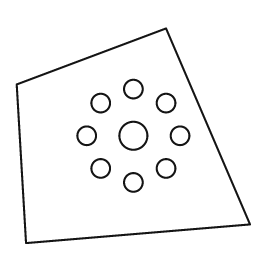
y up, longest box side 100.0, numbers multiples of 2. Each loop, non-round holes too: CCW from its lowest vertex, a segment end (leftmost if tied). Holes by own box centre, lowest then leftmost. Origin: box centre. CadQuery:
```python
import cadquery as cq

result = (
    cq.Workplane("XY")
    .moveTo(-46.0, -46.0)
    .lineTo(50.0, -38.0)
    .lineTo(14.0, 46.0)
    .lineTo(-50.0, 22.0)
    .close()
    .moveTo(0.0, -20.0)
    .circle(4.0)
    .moveTo(-14.0, -14.0)
    .circle(4.0)
    .moveTo(14.0, -14.0)
    .circle(4.0)
    .moveTo(-20.0, 0.0)
    .circle(4.0)
    .moveTo(0.0, 0.0)
    .circle(6.0)
    .moveTo(20.0, 0.0)
    .circle(4.0)
    .moveTo(-14.0, 14.0)
    .circle(4.0)
    .moveTo(14.0, 14.0)
    .circle(4.0)
    .moveTo(0.0, 20.0)
    .circle(4.0)
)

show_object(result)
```